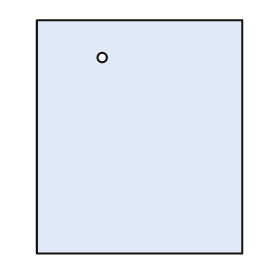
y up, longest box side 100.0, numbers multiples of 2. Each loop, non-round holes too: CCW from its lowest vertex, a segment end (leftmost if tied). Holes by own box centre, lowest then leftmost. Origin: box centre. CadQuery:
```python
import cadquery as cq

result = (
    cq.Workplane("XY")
    .moveTo(-44.0, -50.0)
    .lineTo(44.0, -50.0)
    .lineTo(44.0, 50.0)
    .lineTo(-44.0, 50.0)
    .close()
    .moveTo(-16.0, 34.0)
    .circle(2.0)
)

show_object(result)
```